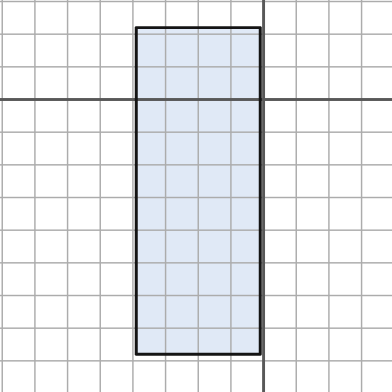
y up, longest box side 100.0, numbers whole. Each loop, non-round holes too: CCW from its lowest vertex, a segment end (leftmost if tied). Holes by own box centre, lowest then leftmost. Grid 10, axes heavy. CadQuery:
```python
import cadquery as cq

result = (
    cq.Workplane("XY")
    .moveTo(-39.0, -78.0)
    .lineTo(-1.0, -78.0)
    .lineTo(-1.0, 22.0)
    .lineTo(-39.0, 22.0)
    .close()
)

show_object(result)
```